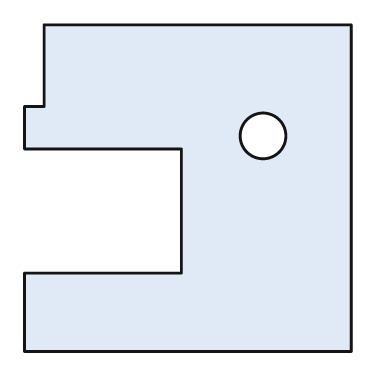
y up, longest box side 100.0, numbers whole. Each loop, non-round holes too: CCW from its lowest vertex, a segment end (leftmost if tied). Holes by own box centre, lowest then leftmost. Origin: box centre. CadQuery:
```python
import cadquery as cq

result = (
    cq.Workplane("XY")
    .moveTo(-50.0, -50.0)
    .lineTo(50.0, -50.0)
    .lineTo(50.0, 50.0)
    .lineTo(-44.0, 50.0)
    .lineTo(-44.0, 25.0)
    .lineTo(-50.0, 25.0)
    .lineTo(-50.0, 12.0)
    .lineTo(-2.0, 12.0)
    .lineTo(-2.0, -26.0)
    .lineTo(-50.0, -26.0)
    .close()
    .moveTo(23.0, 16.0)
    .circle(7.0)
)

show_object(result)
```